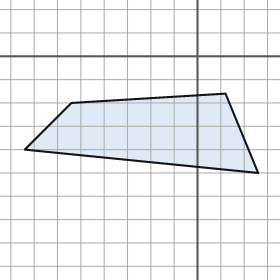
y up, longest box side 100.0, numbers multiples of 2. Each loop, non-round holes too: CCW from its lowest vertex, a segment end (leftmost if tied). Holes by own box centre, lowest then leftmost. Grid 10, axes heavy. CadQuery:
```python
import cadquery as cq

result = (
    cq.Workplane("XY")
    .moveTo(26.0, -50.0)
    .lineTo(12.0, -16.0)
    .lineTo(-54.0, -20.0)
    .lineTo(-74.0, -40.0)
    .close()
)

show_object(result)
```